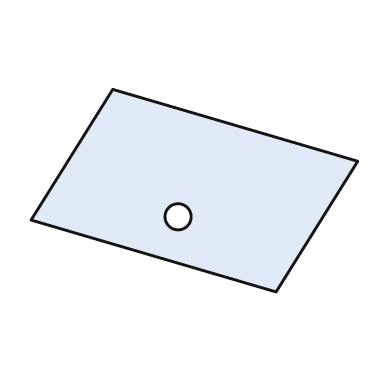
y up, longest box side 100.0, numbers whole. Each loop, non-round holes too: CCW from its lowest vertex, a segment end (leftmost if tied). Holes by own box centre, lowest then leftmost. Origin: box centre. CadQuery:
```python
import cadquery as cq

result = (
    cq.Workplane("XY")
    .moveTo(25.0, -31.0)
    .lineTo(50.0, 9.0)
    .lineTo(-25.0, 31.0)
    .lineTo(-50.0, -9.0)
    .close()
    .moveTo(-5.0, -8.0)
    .circle(4.0)
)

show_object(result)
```